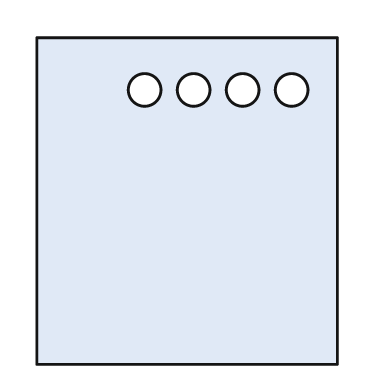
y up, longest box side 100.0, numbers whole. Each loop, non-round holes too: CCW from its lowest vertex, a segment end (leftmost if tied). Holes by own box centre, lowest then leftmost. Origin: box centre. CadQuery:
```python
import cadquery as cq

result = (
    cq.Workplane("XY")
    .moveTo(-46.0, -50.0)
    .lineTo(46.0, -50.0)
    .lineTo(46.0, 50.0)
    .lineTo(-46.0, 50.0)
    .close()
    .moveTo(-13.0, 34.0)
    .circle(5.0)
    .moveTo(2.0, 34.0)
    .circle(5.0)
    .moveTo(17.0, 34.0)
    .circle(5.0)
    .moveTo(32.0, 34.0)
    .circle(5.0)
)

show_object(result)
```